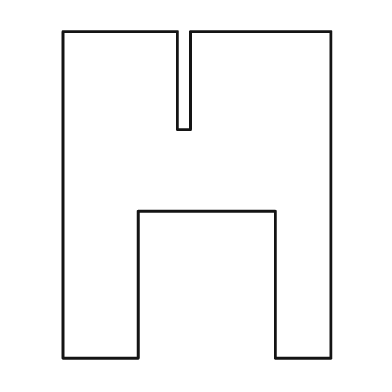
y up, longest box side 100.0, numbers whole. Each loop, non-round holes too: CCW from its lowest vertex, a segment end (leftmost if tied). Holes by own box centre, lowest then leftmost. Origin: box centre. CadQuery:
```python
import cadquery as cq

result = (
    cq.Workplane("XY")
    .moveTo(-41.0, -50.0)
    .lineTo(-18.0, -50.0)
    .lineTo(-18.0, -5.0)
    .lineTo(24.0, -5.0)
    .lineTo(24.0, -50.0)
    .lineTo(41.0, -50.0)
    .lineTo(41.0, 50.0)
    .lineTo(-2.0, 50.0)
    .lineTo(-2.0, 20.0)
    .lineTo(-6.0, 20.0)
    .lineTo(-6.0, 50.0)
    .lineTo(-41.0, 50.0)
    .close()
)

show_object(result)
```